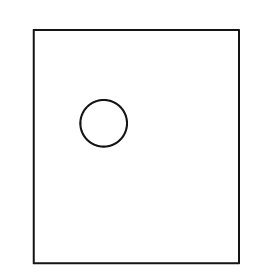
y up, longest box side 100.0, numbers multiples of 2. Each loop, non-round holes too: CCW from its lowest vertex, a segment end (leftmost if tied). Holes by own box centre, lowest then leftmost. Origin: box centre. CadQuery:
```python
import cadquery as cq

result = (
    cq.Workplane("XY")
    .moveTo(-44.0, -50.0)
    .lineTo(44.0, -50.0)
    .lineTo(44.0, 50.0)
    .lineTo(-44.0, 50.0)
    .close()
    .moveTo(-14.0, 10.0)
    .circle(10.0)
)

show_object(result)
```